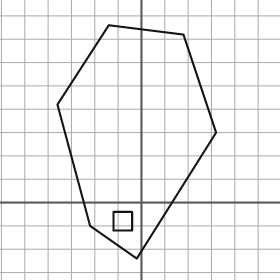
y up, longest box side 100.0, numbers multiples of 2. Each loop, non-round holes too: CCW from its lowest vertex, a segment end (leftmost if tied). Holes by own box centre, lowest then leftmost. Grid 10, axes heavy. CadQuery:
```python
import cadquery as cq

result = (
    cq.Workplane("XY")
    .moveTo(-2.0, -24.0)
    .lineTo(32.0, 30.0)
    .lineTo(18.0, 72.0)
    .lineTo(-14.0, 76.0)
    .lineTo(-36.0, 42.0)
    .lineTo(-22.0, -10.0)
    .close()
    .moveTo(-12.0, -12.0)
    .lineTo(-4.0, -12.0)
    .lineTo(-4.0, -4.0)
    .lineTo(-12.0, -4.0)
    .close()
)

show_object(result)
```